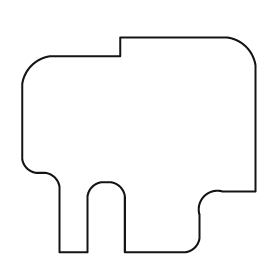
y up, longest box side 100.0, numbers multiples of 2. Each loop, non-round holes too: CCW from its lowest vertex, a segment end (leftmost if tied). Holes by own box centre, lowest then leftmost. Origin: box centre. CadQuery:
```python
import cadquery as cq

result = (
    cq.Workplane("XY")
    .moveTo(-34.0, -46.0)
    .lineTo(-22.0, -46.0)
    .lineTo(-22.0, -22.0)
    .threePointArc((-20.0, -18.0), (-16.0, -16.0))
    .lineTo(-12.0, -16.0)
    .threePointArc((-8.0, -18.0), (-6.0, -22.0))
    .lineTo(-6.0, -46.0)
    .lineTo(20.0, -46.0)
    .threePointArc((24.0, -44.0), (26.0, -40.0))
    .lineTo(26.0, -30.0)
    .threePointArc((28.0, -22.0), (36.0, -20.0))
    .lineTo(50.0, -20.0)
    .lineTo(50.0, 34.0)
    .threePointArc((46.0, 42.0), (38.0, 46.0))
    .lineTo(-8.0, 46.0)
    .lineTo(-8.0, 38.0)
    .lineTo(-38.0, 38.0)
    .threePointArc((-46.0, 34.0), (-50.0, 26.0))
    .lineTo(-50.0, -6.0)
    .threePointArc((-48.0, -10.0), (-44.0, -12.0))
    .lineTo(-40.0, -12.0)
    .threePointArc((-36.0, -14.0), (-34.0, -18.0))
    .close()
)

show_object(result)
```